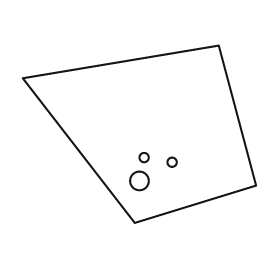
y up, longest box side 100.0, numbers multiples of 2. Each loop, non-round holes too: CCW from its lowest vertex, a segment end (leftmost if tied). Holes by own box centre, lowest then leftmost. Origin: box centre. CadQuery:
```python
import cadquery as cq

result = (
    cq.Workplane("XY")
    .moveTo(-2.0, -38.0)
    .lineTo(50.0, -22.0)
    .lineTo(34.0, 38.0)
    .lineTo(-50.0, 24.0)
    .close()
    .moveTo(0.0, -20.0)
    .circle(4.0)
    .moveTo(14.0, -12.0)
    .circle(2.0)
    .moveTo(2.0, -10.0)
    .circle(2.0)
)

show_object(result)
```